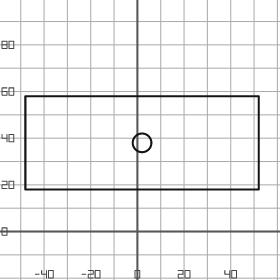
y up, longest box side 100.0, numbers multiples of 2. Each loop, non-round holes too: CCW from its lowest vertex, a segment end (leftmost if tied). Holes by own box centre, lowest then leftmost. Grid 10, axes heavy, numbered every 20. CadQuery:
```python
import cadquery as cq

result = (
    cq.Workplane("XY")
    .moveTo(-48.0, 18.0)
    .lineTo(52.0, 18.0)
    .lineTo(52.0, 58.0)
    .lineTo(-48.0, 58.0)
    .close()
    .moveTo(2.0, 38.0)
    .circle(4.0)
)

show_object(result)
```